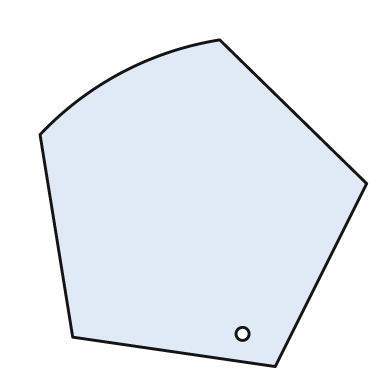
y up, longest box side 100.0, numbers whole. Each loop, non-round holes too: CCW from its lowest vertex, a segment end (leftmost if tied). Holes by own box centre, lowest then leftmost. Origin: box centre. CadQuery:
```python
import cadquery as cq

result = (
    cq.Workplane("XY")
    .moveTo(22.0, -50.0)
    .lineTo(50.0, 6.0)
    .lineTo(5.0, 50.0)
    .threePointArc((-25.0, 40.0), (-50.0, 21.0))
    .lineTo(-40.0, -41.0)
    .close()
    .moveTo(12.0, -40.0)
    .circle(2.0)
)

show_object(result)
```